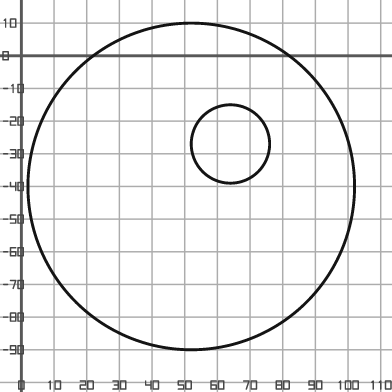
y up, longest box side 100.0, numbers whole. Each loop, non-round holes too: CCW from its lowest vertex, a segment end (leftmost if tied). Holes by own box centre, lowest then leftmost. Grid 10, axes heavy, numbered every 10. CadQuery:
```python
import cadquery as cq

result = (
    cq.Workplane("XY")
    .moveTo(52.0, -40.0)
    .circle(50.0)
    .moveTo(64.0, -27.0)
    .circle(12.0)
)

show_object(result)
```